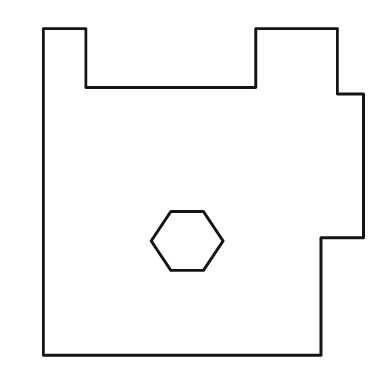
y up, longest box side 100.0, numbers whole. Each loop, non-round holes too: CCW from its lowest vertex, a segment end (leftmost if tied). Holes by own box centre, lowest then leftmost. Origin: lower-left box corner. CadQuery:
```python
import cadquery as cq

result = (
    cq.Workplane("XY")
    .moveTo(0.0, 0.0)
    .lineTo(85.0, 0.0)
    .lineTo(85.0, 36.0)
    .lineTo(98.0, 36.0)
    .lineTo(98.0, 80.0)
    .lineTo(90.0, 80.0)
    .lineTo(90.0, 100.0)
    .lineTo(65.0, 100.0)
    .lineTo(65.0, 82.0)
    .lineTo(13.0, 82.0)
    .lineTo(13.0, 100.0)
    .lineTo(0.0, 100.0)
    .close()
    .moveTo(39.0, 26.0)
    .lineTo(49.0, 26.0)
    .lineTo(55.0, 35.0)
    .lineTo(49.0, 44.0)
    .lineTo(39.0, 44.0)
    .lineTo(33.0, 35.0)
    .close()
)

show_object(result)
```